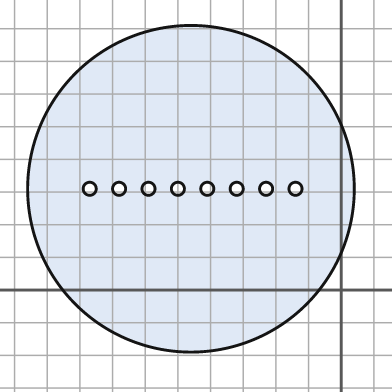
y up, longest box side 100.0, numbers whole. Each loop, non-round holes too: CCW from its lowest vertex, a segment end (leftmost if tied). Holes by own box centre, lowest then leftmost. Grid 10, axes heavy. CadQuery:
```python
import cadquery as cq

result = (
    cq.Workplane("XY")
    .moveTo(-46.0, 31.0)
    .circle(50.0)
    .moveTo(-77.0, 31.0)
    .circle(2.0)
    .moveTo(-68.0, 31.0)
    .circle(2.0)
    .moveTo(-59.0, 31.0)
    .circle(2.0)
    .moveTo(-50.0, 31.0)
    .circle(2.0)
    .moveTo(-41.0, 31.0)
    .circle(2.0)
    .moveTo(-32.0, 31.0)
    .circle(2.0)
    .moveTo(-23.0, 31.0)
    .circle(2.0)
    .moveTo(-14.0, 31.0)
    .circle(2.0)
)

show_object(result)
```